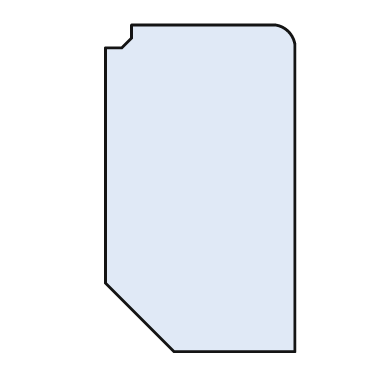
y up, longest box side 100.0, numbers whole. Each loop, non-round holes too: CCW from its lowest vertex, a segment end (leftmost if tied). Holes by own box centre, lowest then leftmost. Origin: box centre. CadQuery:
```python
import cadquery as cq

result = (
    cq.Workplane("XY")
    .moveTo(-8.0, -50.0)
    .lineTo(29.0, -50.0)
    .lineTo(29.0, 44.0)
    .threePointArc((27.0, 48.0), (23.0, 50.0))
    .lineTo(-21.0, 50.0)
    .lineTo(-21.0, 46.0)
    .lineTo(-24.0, 43.0)
    .lineTo(-29.0, 43.0)
    .lineTo(-29.0, -29.0)
    .close()
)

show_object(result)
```